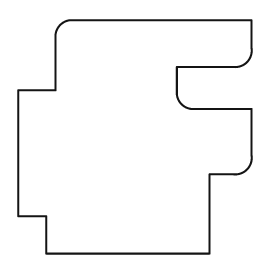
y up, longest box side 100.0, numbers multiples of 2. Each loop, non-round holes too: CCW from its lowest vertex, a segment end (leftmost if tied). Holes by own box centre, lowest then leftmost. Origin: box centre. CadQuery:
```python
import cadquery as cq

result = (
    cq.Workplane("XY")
    .moveTo(-38.0, -50.0)
    .lineTo(32.0, -50.0)
    .lineTo(32.0, -16.0)
    .lineTo(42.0, -16.0)
    .threePointArc((48.0, -14.0), (50.0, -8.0))
    .lineTo(50.0, 12.0)
    .lineTo(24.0, 12.0)
    .threePointArc((20.0, 14.0), (18.0, 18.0))
    .lineTo(18.0, 30.0)
    .lineTo(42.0, 30.0)
    .threePointArc((48.0, 32.0), (50.0, 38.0))
    .lineTo(50.0, 50.0)
    .lineTo(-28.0, 50.0)
    .threePointArc((-32.0, 48.0), (-34.0, 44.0))
    .lineTo(-34.0, 20.0)
    .lineTo(-50.0, 20.0)
    .lineTo(-50.0, -34.0)
    .lineTo(-38.0, -34.0)
    .close()
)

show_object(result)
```